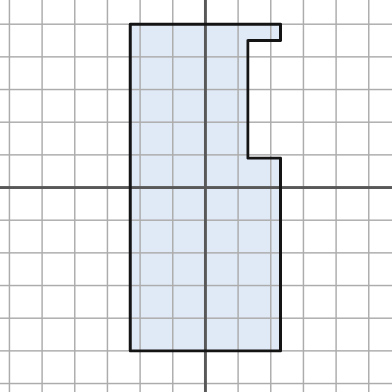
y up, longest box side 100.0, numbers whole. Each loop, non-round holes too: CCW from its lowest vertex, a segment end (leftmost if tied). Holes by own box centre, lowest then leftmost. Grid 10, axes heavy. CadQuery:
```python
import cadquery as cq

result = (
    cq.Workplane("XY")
    .moveTo(-23.0, -50.0)
    .lineTo(23.0, -50.0)
    .lineTo(23.0, 9.0)
    .lineTo(13.0, 9.0)
    .lineTo(13.0, 45.0)
    .lineTo(23.0, 45.0)
    .lineTo(23.0, 50.0)
    .lineTo(-23.0, 50.0)
    .close()
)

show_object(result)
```